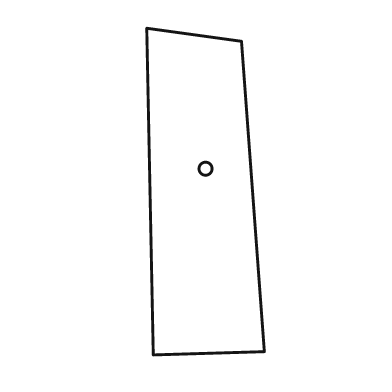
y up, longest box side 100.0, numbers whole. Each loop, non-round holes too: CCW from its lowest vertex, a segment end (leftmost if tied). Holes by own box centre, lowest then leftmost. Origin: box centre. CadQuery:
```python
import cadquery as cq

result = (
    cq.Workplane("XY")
    .moveTo(-16.0, -50.0)
    .lineTo(18.0, -49.0)
    .lineTo(11.0, 46.0)
    .lineTo(-18.0, 50.0)
    .close()
    .moveTo(0.0, 7.0)
    .circle(2.0)
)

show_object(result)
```